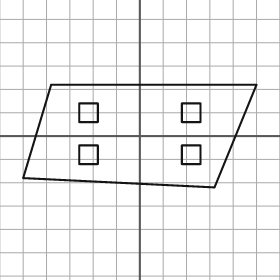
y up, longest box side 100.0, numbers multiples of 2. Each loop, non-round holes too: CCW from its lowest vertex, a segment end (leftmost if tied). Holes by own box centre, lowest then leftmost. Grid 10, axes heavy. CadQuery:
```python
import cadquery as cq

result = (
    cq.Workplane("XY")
    .moveTo(32.0, -22.0)
    .lineTo(50.0, 22.0)
    .lineTo(-38.0, 22.0)
    .lineTo(-50.0, -18.0)
    .close()
    .moveTo(-26.0, -12.0)
    .lineTo(-18.0, -12.0)
    .lineTo(-18.0, -4.0)
    .lineTo(-26.0, -4.0)
    .close()
    .moveTo(18.0, -12.0)
    .lineTo(26.0, -12.0)
    .lineTo(26.0, -4.0)
    .lineTo(18.0, -4.0)
    .close()
    .moveTo(-26.0, 6.0)
    .lineTo(-18.0, 6.0)
    .lineTo(-18.0, 14.0)
    .lineTo(-26.0, 14.0)
    .close()
    .moveTo(18.0, 6.0)
    .lineTo(26.0, 6.0)
    .lineTo(26.0, 14.0)
    .lineTo(18.0, 14.0)
    .close()
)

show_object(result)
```